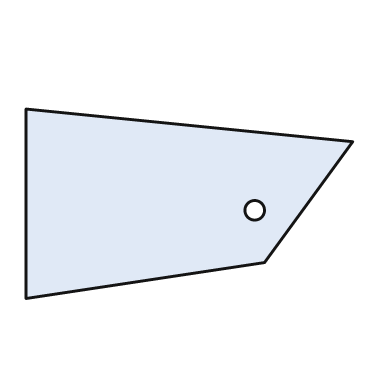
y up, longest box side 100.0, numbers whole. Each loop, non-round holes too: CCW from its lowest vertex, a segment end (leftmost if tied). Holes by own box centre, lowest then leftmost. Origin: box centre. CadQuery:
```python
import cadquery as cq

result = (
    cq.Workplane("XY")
    .moveTo(-50.0, -29.0)
    .lineTo(23.0, -18.0)
    .lineTo(50.0, 19.0)
    .lineTo(-50.0, 29.0)
    .close()
    .moveTo(20.0, -2.0)
    .circle(3.0)
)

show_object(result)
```